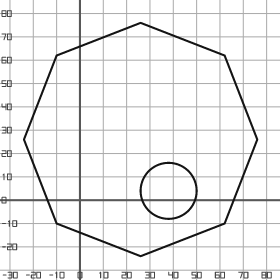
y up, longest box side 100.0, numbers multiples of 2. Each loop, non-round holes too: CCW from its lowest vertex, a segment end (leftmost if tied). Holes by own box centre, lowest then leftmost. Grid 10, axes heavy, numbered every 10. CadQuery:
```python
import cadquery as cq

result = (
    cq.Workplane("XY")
    .moveTo(26.0, -24.0)
    .lineTo(62.0, -10.0)
    .lineTo(76.0, 26.0)
    .lineTo(62.0, 62.0)
    .lineTo(26.0, 76.0)
    .lineTo(-10.0, 62.0)
    .lineTo(-24.0, 26.0)
    .lineTo(-10.0, -10.0)
    .close()
    .moveTo(38.0, 4.0)
    .circle(12.0)
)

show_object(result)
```